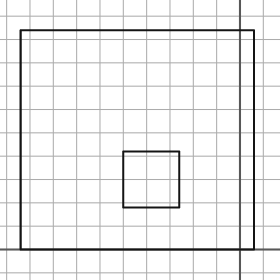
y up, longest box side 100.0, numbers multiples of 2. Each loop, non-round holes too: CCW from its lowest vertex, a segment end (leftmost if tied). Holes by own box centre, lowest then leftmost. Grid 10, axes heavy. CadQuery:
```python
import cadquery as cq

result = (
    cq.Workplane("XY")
    .moveTo(-94.0, 0.0)
    .lineTo(6.0, 0.0)
    .lineTo(6.0, 94.0)
    .lineTo(-94.0, 94.0)
    .close()
    .moveTo(-50.0, 18.0)
    .lineTo(-26.0, 18.0)
    .lineTo(-26.0, 42.0)
    .lineTo(-50.0, 42.0)
    .close()
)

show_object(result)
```